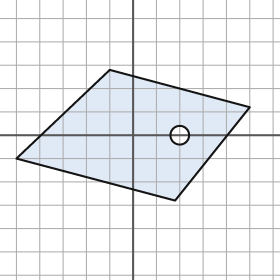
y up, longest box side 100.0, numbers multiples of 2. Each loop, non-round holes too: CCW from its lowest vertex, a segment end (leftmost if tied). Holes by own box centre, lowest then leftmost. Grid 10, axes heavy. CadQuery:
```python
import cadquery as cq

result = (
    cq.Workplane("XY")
    .moveTo(18.0, -28.0)
    .lineTo(50.0, 12.0)
    .lineTo(-10.0, 28.0)
    .lineTo(-50.0, -10.0)
    .close()
    .moveTo(20.0, 0.0)
    .circle(4.0)
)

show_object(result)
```